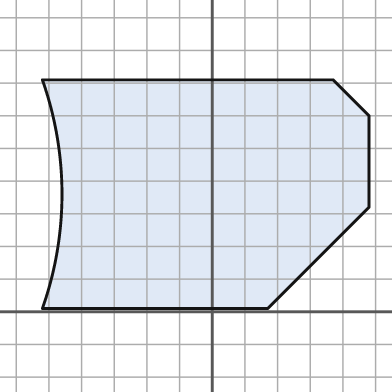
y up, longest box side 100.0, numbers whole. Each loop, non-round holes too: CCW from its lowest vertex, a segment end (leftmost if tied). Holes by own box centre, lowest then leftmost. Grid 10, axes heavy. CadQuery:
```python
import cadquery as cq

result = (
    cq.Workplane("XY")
    .moveTo(-52.0, 1.0)
    .lineTo(17.0, 1.0)
    .lineTo(48.0, 32.0)
    .lineTo(48.0, 60.0)
    .lineTo(37.0, 71.0)
    .lineTo(-52.0, 71.0)
    .threePointArc((-46.0, 36.0), (-52.0, 1.0))
    .close()
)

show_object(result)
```